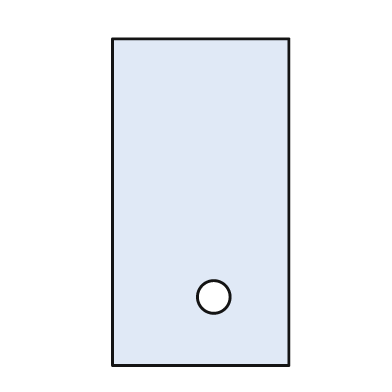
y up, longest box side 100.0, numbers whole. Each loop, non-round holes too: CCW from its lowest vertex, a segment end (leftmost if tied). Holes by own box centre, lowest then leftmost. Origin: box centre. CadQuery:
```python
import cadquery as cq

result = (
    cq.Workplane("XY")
    .moveTo(-27.0, -50.0)
    .lineTo(27.0, -50.0)
    .lineTo(27.0, 50.0)
    .lineTo(-27.0, 50.0)
    .close()
    .moveTo(4.0, -29.0)
    .circle(5.0)
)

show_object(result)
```